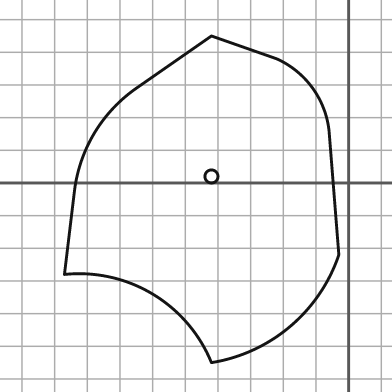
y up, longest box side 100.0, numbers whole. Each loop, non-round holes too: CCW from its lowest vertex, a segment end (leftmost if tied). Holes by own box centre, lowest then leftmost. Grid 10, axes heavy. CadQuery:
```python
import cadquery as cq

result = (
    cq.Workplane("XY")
    .moveTo(-42.0, -55.0)
    .threePointArc((-18.0, -44.0), (-3.0, -22.0))
    .lineTo(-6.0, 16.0)
    .threePointArc((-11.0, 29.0), (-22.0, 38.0))
    .lineTo(-42.0, 45.0)
    .lineTo(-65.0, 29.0)
    .threePointArc((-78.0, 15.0), (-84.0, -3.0))
    .lineTo(-87.0, -28.0)
    .threePointArc((-60.0, -34.0), (-42.0, -55.0))
    .close()
    .moveTo(-42.0, 2.0)
    .circle(2.0)
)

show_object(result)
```